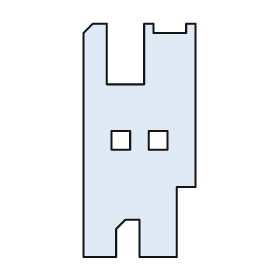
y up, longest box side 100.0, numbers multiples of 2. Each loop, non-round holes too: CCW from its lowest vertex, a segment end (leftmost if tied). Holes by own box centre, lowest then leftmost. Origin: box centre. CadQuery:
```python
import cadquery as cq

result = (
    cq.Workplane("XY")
    .moveTo(-24.0, -50.0)
    .lineTo(-10.0, -50.0)
    .lineTo(-10.0, -38.0)
    .lineTo(-6.0, -34.0)
    .lineTo(0.0, -34.0)
    .lineTo(0.0, -50.0)
    .lineTo(16.0, -50.0)
    .lineTo(16.0, -20.0)
    .lineTo(24.0, -20.0)
    .lineTo(24.0, 50.0)
    .lineTo(20.0, 50.0)
    .lineTo(20.0, 46.0)
    .lineTo(6.0, 46.0)
    .lineTo(6.0, 50.0)
    .lineTo(2.0, 50.0)
    .lineTo(2.0, 24.0)
    .lineTo(-14.0, 24.0)
    .lineTo(-14.0, 50.0)
    .lineTo(-20.0, 50.0)
    .lineTo(-24.0, 46.0)
    .close()
    .moveTo(-12.0, -4.0)
    .lineTo(-4.0, -4.0)
    .lineTo(-4.0, 4.0)
    .lineTo(-12.0, 4.0)
    .close()
    .moveTo(4.0, -4.0)
    .lineTo(12.0, -4.0)
    .lineTo(12.0, 4.0)
    .lineTo(4.0, 4.0)
    .close()
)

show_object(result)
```